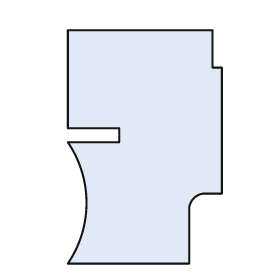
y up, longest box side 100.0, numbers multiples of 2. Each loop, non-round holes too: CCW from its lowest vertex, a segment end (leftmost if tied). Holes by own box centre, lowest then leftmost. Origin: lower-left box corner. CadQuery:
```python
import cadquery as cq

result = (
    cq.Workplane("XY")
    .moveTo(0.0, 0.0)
    .lineTo(52.0, 0.0)
    .lineTo(52.0, 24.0)
    .threePointArc((54.0, 28.0), (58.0, 30.0))
    .lineTo(66.0, 30.0)
    .lineTo(66.0, 84.0)
    .lineTo(62.0, 84.0)
    .lineTo(62.0, 100.0)
    .lineTo(0.0, 100.0)
    .lineTo(0.0, 58.0)
    .lineTo(22.0, 58.0)
    .lineTo(22.0, 52.0)
    .lineTo(0.0, 52.0)
    .threePointArc((8.0, 26.0), (0.0, 0.0))
    .close()
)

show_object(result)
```